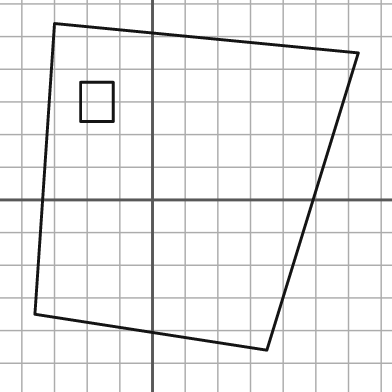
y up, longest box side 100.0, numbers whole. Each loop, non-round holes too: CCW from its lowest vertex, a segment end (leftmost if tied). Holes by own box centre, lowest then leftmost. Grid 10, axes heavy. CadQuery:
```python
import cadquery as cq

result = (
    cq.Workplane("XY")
    .moveTo(35.0, -46.0)
    .lineTo(63.0, 45.0)
    .lineTo(-30.0, 54.0)
    .lineTo(-36.0, -35.0)
    .close()
    .moveTo(-22.0, 24.0)
    .lineTo(-12.0, 24.0)
    .lineTo(-12.0, 36.0)
    .lineTo(-22.0, 36.0)
    .close()
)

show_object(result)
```